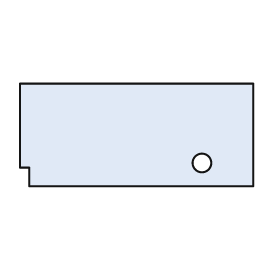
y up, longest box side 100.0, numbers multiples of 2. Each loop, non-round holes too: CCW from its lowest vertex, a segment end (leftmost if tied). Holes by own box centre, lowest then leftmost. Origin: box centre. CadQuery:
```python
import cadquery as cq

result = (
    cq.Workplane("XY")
    .moveTo(-46.0, -22.0)
    .lineTo(50.0, -22.0)
    .lineTo(50.0, 22.0)
    .lineTo(-50.0, 22.0)
    .lineTo(-50.0, -14.0)
    .lineTo(-46.0, -14.0)
    .close()
    .moveTo(28.0, -12.0)
    .circle(4.0)
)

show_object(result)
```